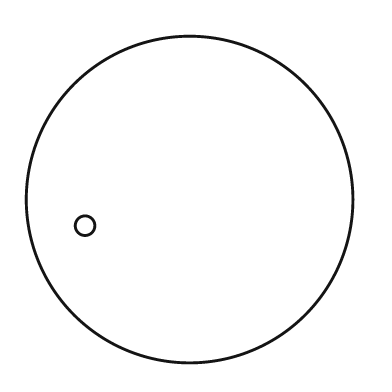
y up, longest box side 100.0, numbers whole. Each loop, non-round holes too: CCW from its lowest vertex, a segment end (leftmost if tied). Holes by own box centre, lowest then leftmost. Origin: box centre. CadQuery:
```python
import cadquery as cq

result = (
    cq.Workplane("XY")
    .moveTo(0.0, 0.0)
    .circle(50.0)
    .moveTo(-32.0, -8.0)
    .circle(3.0)
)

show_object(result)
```